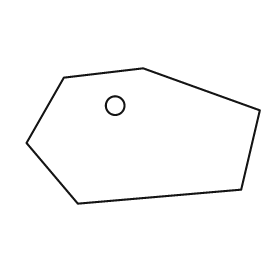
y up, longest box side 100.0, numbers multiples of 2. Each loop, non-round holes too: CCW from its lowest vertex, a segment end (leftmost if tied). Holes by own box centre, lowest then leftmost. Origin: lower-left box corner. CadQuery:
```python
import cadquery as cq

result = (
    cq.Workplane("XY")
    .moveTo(22.0, 0.0)
    .lineTo(92.0, 6.0)
    .lineTo(100.0, 40.0)
    .lineTo(50.0, 58.0)
    .lineTo(16.0, 54.0)
    .lineTo(0.0, 26.0)
    .close()
    .moveTo(38.0, 42.0)
    .circle(4.0)
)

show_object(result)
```